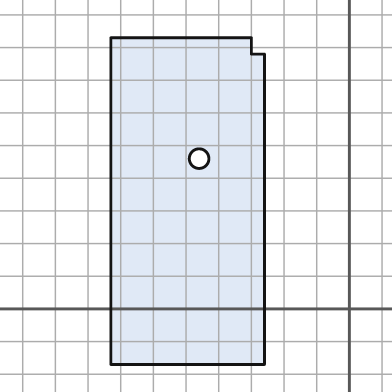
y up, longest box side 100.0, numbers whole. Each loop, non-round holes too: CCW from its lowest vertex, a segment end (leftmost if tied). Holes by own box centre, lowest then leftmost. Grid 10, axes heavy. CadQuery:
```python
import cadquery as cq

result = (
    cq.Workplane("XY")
    .moveTo(-73.0, -17.0)
    .lineTo(-26.0, -17.0)
    .lineTo(-26.0, 78.0)
    .lineTo(-30.0, 78.0)
    .lineTo(-30.0, 83.0)
    .lineTo(-73.0, 83.0)
    .close()
    .moveTo(-46.0, 46.0)
    .circle(3.0)
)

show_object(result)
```